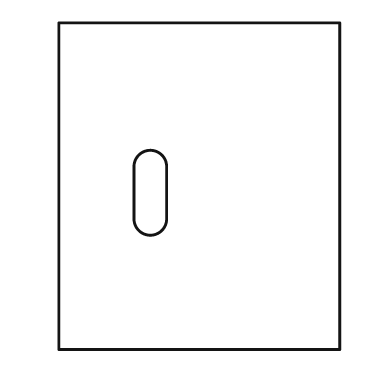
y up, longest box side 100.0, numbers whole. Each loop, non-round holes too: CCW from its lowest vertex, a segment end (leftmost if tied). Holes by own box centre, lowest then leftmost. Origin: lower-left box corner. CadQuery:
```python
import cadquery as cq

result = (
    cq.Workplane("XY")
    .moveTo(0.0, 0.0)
    .lineTo(86.0, 0.0)
    .lineTo(86.0, 100.0)
    .lineTo(0.0, 100.0)
    .close()
    .moveTo(23.0, 40.0)
    .threePointArc((28.0, 35.0), (33.0, 40.0))
    .lineTo(33.0, 56.0)
    .threePointArc((28.0, 61.0), (23.0, 56.0))
    .close()
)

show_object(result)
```